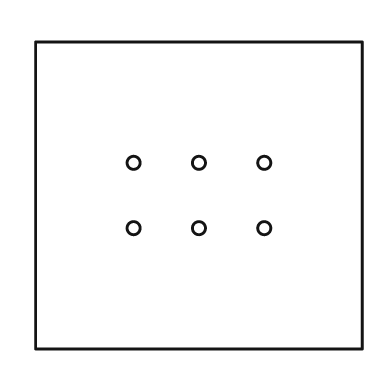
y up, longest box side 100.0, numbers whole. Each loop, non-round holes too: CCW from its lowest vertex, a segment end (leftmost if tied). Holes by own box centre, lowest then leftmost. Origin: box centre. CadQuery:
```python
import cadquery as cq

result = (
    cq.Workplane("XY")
    .moveTo(-50.0, -47.0)
    .lineTo(50.0, -47.0)
    .lineTo(50.0, 47.0)
    .lineTo(-50.0, 47.0)
    .close()
    .moveTo(-20.0, -10.0)
    .circle(2.0)
    .moveTo(0.0, -10.0)
    .circle(2.0)
    .moveTo(20.0, -10.0)
    .circle(2.0)
    .moveTo(-20.0, 10.0)
    .circle(2.0)
    .moveTo(0.0, 10.0)
    .circle(2.0)
    .moveTo(20.0, 10.0)
    .circle(2.0)
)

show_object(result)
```